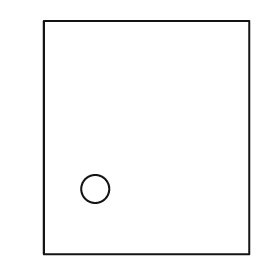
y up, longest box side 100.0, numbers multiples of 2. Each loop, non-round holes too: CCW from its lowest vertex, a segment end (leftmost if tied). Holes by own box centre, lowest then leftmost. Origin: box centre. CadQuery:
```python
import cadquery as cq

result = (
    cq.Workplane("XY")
    .moveTo(-44.0, -50.0)
    .lineTo(44.0, -50.0)
    .lineTo(44.0, 50.0)
    .lineTo(-44.0, 50.0)
    .close()
    .moveTo(-22.0, -22.0)
    .circle(6.0)
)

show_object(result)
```